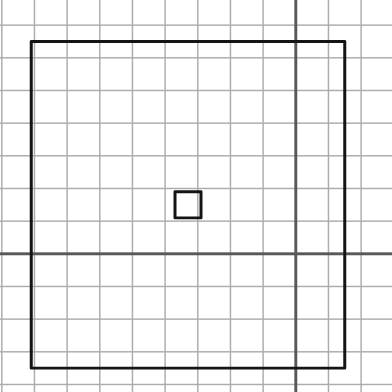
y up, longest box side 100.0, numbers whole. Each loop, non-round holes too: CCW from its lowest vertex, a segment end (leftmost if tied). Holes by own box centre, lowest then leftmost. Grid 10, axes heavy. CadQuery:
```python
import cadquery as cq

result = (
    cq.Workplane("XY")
    .moveTo(-81.0, -35.0)
    .lineTo(15.0, -35.0)
    .lineTo(15.0, 65.0)
    .lineTo(-81.0, 65.0)
    .close()
    .moveTo(-37.0, 11.0)
    .lineTo(-29.0, 11.0)
    .lineTo(-29.0, 19.0)
    .lineTo(-37.0, 19.0)
    .close()
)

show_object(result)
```